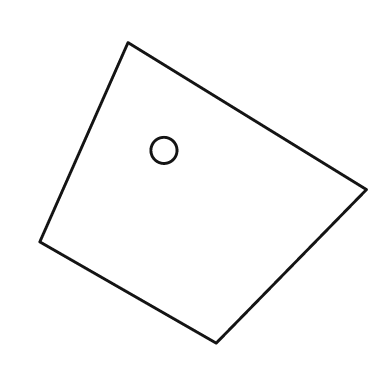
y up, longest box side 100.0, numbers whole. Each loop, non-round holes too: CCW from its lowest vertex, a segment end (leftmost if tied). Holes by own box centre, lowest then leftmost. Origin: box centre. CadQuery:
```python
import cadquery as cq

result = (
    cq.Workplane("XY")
    .moveTo(4.0, -46.0)
    .lineTo(50.0, 1.0)
    .lineTo(-23.0, 46.0)
    .lineTo(-50.0, -15.0)
    .close()
    .moveTo(-12.0, 13.0)
    .circle(4.0)
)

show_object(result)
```